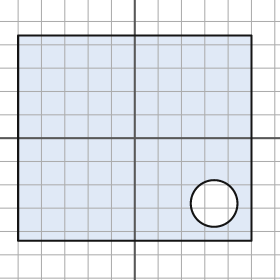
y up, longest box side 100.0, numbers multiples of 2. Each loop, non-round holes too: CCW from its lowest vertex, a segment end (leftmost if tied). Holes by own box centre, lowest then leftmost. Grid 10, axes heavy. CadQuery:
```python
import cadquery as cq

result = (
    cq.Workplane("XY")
    .moveTo(-50.0, -44.0)
    .lineTo(50.0, -44.0)
    .lineTo(50.0, 44.0)
    .lineTo(-50.0, 44.0)
    .close()
    .moveTo(34.0, -28.0)
    .circle(10.0)
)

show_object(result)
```